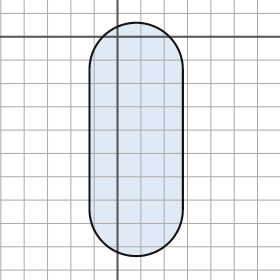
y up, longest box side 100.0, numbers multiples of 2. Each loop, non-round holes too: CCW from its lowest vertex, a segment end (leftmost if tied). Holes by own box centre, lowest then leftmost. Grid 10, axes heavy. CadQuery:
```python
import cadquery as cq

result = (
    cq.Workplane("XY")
    .moveTo(-12.0, -74.0)
    .threePointArc((8.0, -94.0), (28.0, -74.0))
    .lineTo(28.0, -14.0)
    .threePointArc((8.0, 6.0), (-12.0, -14.0))
    .close()
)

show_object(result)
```